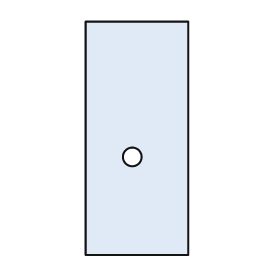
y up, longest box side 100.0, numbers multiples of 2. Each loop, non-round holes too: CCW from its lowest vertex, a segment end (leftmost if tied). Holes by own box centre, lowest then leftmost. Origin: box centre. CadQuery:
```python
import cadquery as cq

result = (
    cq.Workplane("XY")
    .moveTo(-22.0, -50.0)
    .lineTo(22.0, -50.0)
    .lineTo(22.0, 50.0)
    .lineTo(-22.0, 50.0)
    .close()
    .moveTo(-2.0, -8.0)
    .circle(4.0)
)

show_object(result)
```